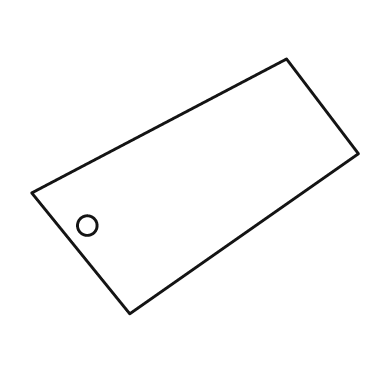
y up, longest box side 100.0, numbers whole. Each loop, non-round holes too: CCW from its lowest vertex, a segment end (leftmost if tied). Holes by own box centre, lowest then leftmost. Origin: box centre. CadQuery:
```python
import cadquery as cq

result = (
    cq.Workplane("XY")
    .moveTo(-20.0, -39.0)
    .lineTo(50.0, 10.0)
    .lineTo(28.0, 39.0)
    .lineTo(-50.0, -2.0)
    .close()
    .moveTo(-33.0, -12.0)
    .circle(3.0)
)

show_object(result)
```